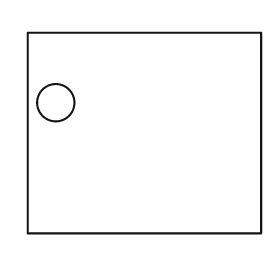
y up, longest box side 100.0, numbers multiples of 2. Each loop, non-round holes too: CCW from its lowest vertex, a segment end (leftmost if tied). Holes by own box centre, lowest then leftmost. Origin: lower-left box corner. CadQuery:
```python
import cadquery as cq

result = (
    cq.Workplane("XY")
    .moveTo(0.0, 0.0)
    .lineTo(100.0, 0.0)
    .lineTo(100.0, 86.0)
    .lineTo(0.0, 86.0)
    .close()
    .moveTo(12.0, 56.0)
    .circle(8.0)
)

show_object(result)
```